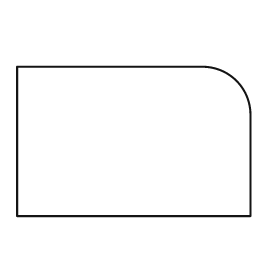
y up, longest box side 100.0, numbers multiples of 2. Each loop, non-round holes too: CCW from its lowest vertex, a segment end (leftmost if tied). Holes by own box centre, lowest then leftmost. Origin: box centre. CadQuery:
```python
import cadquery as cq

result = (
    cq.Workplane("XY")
    .moveTo(-50.0, -32.0)
    .lineTo(50.0, -32.0)
    .lineTo(50.0, 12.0)
    .threePointArc((44.0, 26.0), (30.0, 32.0))
    .lineTo(-50.0, 32.0)
    .close()
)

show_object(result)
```